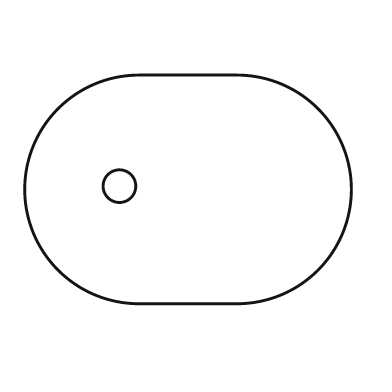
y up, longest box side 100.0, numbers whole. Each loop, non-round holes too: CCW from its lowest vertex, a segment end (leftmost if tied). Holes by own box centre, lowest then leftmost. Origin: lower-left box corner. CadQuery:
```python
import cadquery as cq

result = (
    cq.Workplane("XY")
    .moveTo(35.0, 0.0)
    .lineTo(65.0, 0.0)
    .threePointArc((100.0, 35.0), (65.0, 70.0))
    .lineTo(35.0, 70.0)
    .threePointArc((0.0, 35.0), (35.0, 0.0))
    .close()
    .moveTo(29.0, 36.0)
    .circle(5.0)
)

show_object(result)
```